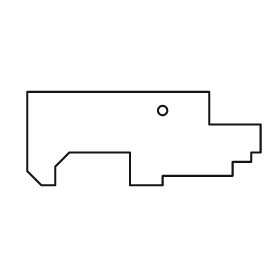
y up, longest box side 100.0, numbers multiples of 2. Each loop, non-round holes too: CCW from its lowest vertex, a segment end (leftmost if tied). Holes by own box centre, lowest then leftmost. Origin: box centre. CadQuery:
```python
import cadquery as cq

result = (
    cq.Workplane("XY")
    .moveTo(-44.0, -20.0)
    .lineTo(-38.0, -20.0)
    .lineTo(-38.0, -12.0)
    .lineTo(-32.0, -6.0)
    .lineTo(-6.0, -6.0)
    .lineTo(-6.0, -20.0)
    .lineTo(8.0, -20.0)
    .lineTo(8.0, -16.0)
    .lineTo(38.0, -16.0)
    .lineTo(38.0, -10.0)
    .lineTo(46.0, -10.0)
    .lineTo(46.0, -6.0)
    .lineTo(50.0, -6.0)
    .lineTo(50.0, 6.0)
    .lineTo(28.0, 6.0)
    .lineTo(28.0, 20.0)
    .lineTo(-50.0, 20.0)
    .lineTo(-50.0, -14.0)
    .close()
    .moveTo(8.0, 12.0)
    .circle(2.0)
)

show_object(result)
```